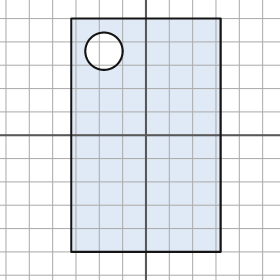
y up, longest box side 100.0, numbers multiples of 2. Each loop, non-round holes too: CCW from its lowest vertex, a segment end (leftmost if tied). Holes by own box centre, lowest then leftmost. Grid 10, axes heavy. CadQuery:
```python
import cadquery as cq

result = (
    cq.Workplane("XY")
    .moveTo(-32.0, -50.0)
    .lineTo(32.0, -50.0)
    .lineTo(32.0, 50.0)
    .lineTo(-32.0, 50.0)
    .close()
    .moveTo(-18.0, 36.0)
    .circle(8.0)
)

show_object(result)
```